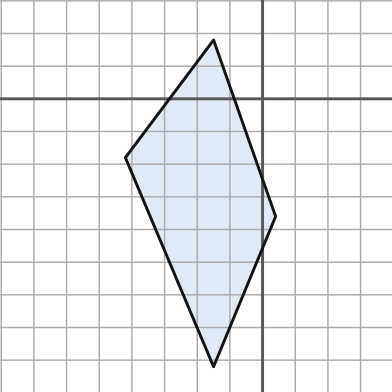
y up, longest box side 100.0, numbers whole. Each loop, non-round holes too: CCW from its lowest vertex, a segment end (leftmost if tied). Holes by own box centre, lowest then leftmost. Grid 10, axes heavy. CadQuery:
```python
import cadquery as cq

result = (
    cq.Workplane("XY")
    .moveTo(-15.0, -82.0)
    .lineTo(4.0, -36.0)
    .lineTo(-15.0, 18.0)
    .lineTo(-42.0, -18.0)
    .close()
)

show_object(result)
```